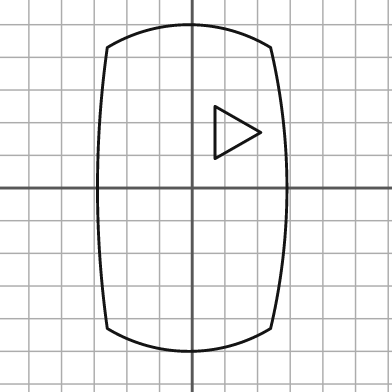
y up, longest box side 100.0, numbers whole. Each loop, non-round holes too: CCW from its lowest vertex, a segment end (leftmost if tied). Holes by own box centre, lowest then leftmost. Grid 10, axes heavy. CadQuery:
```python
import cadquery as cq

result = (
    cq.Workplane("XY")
    .moveTo(-26.0, -43.0)
    .threePointArc((-1.0, -50.0), (24.0, -43.0))
    .threePointArc((29.0, 0.0), (24.0, 43.0))
    .threePointArc((-1.0, 50.0), (-26.0, 43.0))
    .threePointArc((-29.0, 0.0), (-26.0, -43.0))
    .close()
    .moveTo(7.0, 9.0)
    .lineTo(21.0, 17.0)
    .lineTo(7.0, 25.0)
    .close()
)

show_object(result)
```